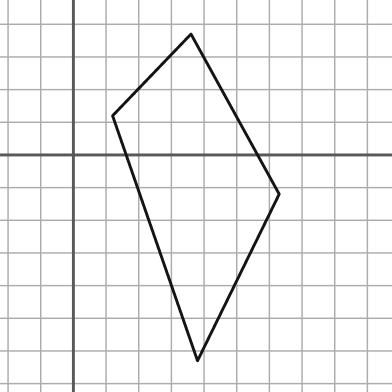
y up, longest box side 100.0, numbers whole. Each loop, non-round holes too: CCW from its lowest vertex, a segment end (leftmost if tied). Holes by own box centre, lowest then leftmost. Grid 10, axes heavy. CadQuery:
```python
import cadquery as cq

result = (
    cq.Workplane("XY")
    .moveTo(38.0, -63.0)
    .lineTo(63.0, -12.0)
    .lineTo(36.0, 37.0)
    .lineTo(12.0, 12.0)
    .close()
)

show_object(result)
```